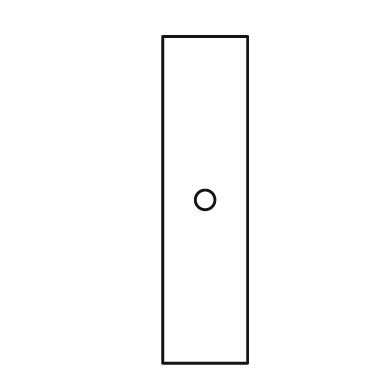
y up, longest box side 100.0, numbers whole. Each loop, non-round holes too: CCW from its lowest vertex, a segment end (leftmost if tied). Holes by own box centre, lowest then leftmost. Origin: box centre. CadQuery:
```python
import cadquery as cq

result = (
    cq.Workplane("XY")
    .moveTo(-13.0, -50.0)
    .lineTo(13.0, -50.0)
    .lineTo(13.0, 50.0)
    .lineTo(-13.0, 50.0)
    .close()
    .moveTo(0.0, 0.0)
    .circle(3.0)
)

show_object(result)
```